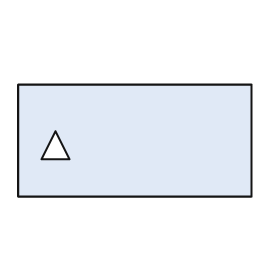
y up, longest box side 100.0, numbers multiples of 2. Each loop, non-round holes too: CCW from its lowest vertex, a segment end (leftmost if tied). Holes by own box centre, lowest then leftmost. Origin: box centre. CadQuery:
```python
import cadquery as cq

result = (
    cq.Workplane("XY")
    .moveTo(-50.0, -24.0)
    .lineTo(50.0, -24.0)
    .lineTo(50.0, 24.0)
    .lineTo(-50.0, 24.0)
    .close()
    .moveTo(-40.0, -8.0)
    .lineTo(-28.0, -8.0)
    .lineTo(-34.0, 4.0)
    .close()
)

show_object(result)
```